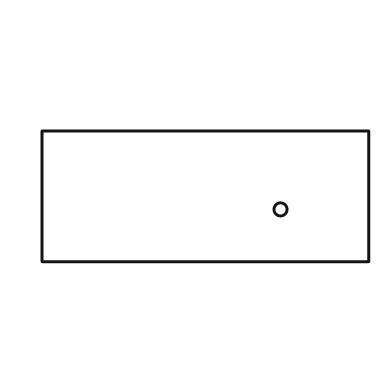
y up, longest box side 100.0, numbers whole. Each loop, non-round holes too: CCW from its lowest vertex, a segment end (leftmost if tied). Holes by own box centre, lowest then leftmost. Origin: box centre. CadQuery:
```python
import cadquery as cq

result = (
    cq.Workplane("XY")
    .moveTo(-50.0, -20.0)
    .lineTo(50.0, -20.0)
    .lineTo(50.0, 20.0)
    .lineTo(-50.0, 20.0)
    .close()
    .moveTo(23.0, -4.0)
    .circle(2.0)
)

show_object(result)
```